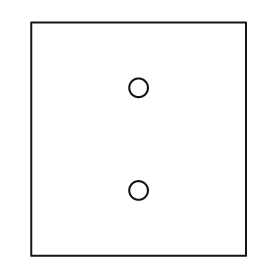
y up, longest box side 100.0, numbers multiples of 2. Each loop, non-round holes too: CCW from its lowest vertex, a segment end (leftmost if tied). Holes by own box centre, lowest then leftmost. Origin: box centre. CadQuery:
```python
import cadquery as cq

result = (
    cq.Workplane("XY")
    .moveTo(-46.0, -50.0)
    .lineTo(46.0, -50.0)
    .lineTo(46.0, 50.0)
    .lineTo(-46.0, 50.0)
    .close()
    .moveTo(0.0, -22.0)
    .circle(4.0)
    .moveTo(0.0, 22.0)
    .circle(4.0)
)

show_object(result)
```